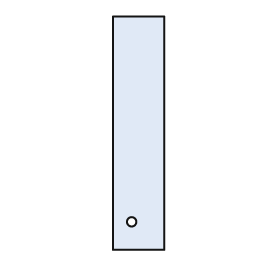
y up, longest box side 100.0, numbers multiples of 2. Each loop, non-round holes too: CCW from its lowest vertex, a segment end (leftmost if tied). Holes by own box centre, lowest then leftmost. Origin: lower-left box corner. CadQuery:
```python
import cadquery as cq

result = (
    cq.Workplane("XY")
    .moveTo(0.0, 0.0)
    .lineTo(22.0, 0.0)
    .lineTo(22.0, 100.0)
    .lineTo(0.0, 100.0)
    .close()
    .moveTo(8.0, 12.0)
    .circle(2.0)
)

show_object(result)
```